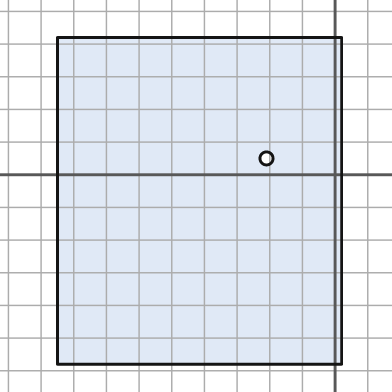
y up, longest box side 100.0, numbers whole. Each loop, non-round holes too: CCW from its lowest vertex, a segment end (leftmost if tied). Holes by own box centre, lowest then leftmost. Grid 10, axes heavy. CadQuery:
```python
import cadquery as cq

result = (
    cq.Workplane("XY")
    .moveTo(-85.0, -58.0)
    .lineTo(2.0, -58.0)
    .lineTo(2.0, 42.0)
    .lineTo(-85.0, 42.0)
    .close()
    .moveTo(-21.0, 5.0)
    .circle(2.0)
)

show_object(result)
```